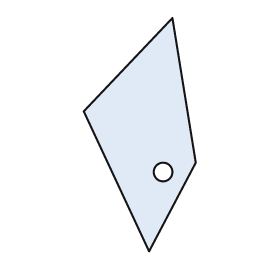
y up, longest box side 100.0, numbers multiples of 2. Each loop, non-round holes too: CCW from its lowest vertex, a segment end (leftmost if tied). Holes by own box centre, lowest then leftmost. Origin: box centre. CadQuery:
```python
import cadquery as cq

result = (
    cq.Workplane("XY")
    .moveTo(4.0, -50.0)
    .lineTo(24.0, -12.0)
    .lineTo(14.0, 50.0)
    .lineTo(-24.0, 10.0)
    .close()
    .moveTo(10.0, -16.0)
    .circle(4.0)
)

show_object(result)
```